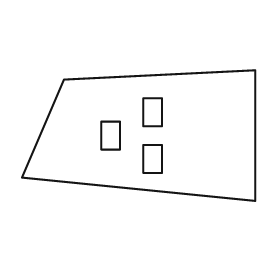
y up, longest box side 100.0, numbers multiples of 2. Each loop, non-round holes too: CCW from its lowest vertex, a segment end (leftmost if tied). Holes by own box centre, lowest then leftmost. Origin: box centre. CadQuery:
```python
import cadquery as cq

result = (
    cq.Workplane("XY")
    .moveTo(50.0, -28.0)
    .lineTo(50.0, 28.0)
    .lineTo(-32.0, 24.0)
    .lineTo(-50.0, -18.0)
    .close()
    .moveTo(2.0, -16.0)
    .lineTo(10.0, -16.0)
    .lineTo(10.0, -4.0)
    .lineTo(2.0, -4.0)
    .close()
    .moveTo(-16.0, -6.0)
    .lineTo(-8.0, -6.0)
    .lineTo(-8.0, 6.0)
    .lineTo(-16.0, 6.0)
    .close()
    .moveTo(2.0, 4.0)
    .lineTo(10.0, 4.0)
    .lineTo(10.0, 16.0)
    .lineTo(2.0, 16.0)
    .close()
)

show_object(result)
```